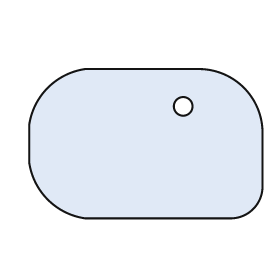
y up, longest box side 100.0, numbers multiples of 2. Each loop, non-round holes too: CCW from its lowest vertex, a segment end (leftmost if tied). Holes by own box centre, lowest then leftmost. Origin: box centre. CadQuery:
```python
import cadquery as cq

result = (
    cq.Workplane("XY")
    .moveTo(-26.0, -32.0)
    .lineTo(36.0, -32.0)
    .threePointArc((46.0, -28.0), (50.0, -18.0))
    .lineTo(50.0, 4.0)
    .threePointArc((42.0, 24.0), (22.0, 32.0))
    .lineTo(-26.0, 32.0)
    .threePointArc((-42.0, 24.0), (-50.0, 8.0))
    .lineTo(-50.0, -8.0)
    .threePointArc((-42.0, -24.0), (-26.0, -32.0))
    .close()
    .moveTo(16.0, 16.0)
    .circle(4.0)
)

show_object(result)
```